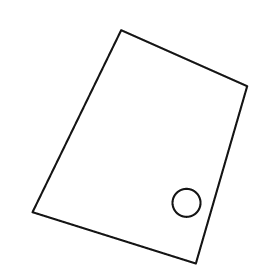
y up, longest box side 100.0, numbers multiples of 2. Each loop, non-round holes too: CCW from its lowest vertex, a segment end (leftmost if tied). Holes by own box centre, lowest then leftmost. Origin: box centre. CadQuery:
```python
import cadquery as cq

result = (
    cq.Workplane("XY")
    .moveTo(24.0, -50.0)
    .lineTo(46.0, 26.0)
    .lineTo(-8.0, 50.0)
    .lineTo(-46.0, -28.0)
    .close()
    .moveTo(20.0, -24.0)
    .circle(6.0)
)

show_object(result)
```